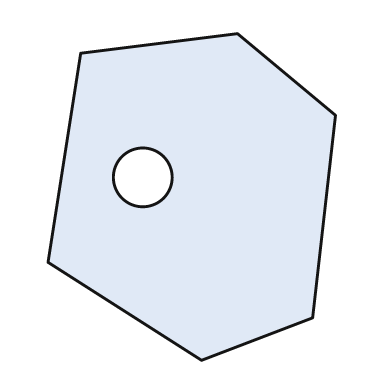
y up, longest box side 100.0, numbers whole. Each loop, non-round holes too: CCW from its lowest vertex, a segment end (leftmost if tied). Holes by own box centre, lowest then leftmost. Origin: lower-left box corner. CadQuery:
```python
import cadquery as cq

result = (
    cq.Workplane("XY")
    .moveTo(47.0, 0.0)
    .lineTo(81.0, 13.0)
    .lineTo(88.0, 75.0)
    .lineTo(58.0, 100.0)
    .lineTo(10.0, 94.0)
    .lineTo(0.0, 30.0)
    .close()
    .moveTo(29.0, 56.0)
    .circle(9.0)
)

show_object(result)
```